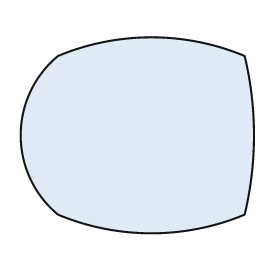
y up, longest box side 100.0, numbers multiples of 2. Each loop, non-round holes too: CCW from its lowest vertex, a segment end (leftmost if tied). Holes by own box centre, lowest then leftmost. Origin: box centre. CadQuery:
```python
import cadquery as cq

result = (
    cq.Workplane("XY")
    .moveTo(-34.0, -34.0)
    .threePointArc((6.0, -42.0), (46.0, -34.0))
    .threePointArc((50.0, 0.0), (46.0, 34.0))
    .threePointArc((6.0, 42.0), (-34.0, 34.0))
    .threePointArc((-50.0, 0.0), (-34.0, -34.0))
    .close()
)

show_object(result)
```